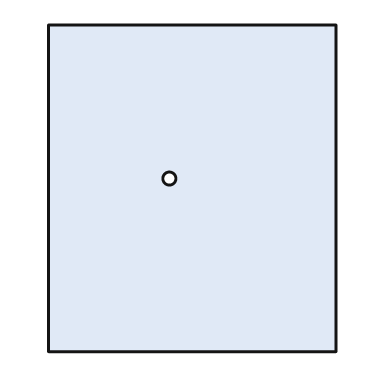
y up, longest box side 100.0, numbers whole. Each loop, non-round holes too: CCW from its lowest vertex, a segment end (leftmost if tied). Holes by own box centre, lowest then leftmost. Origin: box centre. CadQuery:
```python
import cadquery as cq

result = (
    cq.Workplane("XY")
    .moveTo(-44.0, -50.0)
    .lineTo(44.0, -50.0)
    .lineTo(44.0, 50.0)
    .lineTo(-44.0, 50.0)
    .close()
    .moveTo(-7.0, 3.0)
    .circle(2.0)
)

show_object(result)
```